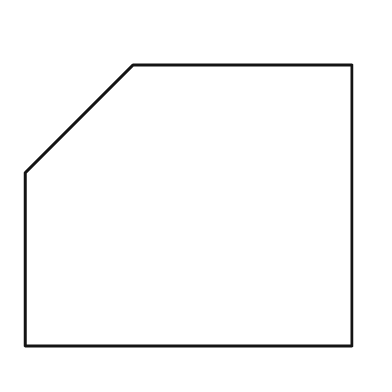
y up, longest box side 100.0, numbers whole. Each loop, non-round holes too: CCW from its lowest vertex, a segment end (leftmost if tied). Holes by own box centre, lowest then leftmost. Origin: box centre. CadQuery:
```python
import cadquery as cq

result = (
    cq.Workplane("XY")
    .moveTo(-50.0, -43.0)
    .lineTo(50.0, -43.0)
    .lineTo(50.0, 43.0)
    .lineTo(-17.0, 43.0)
    .lineTo(-50.0, 10.0)
    .close()
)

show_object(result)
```